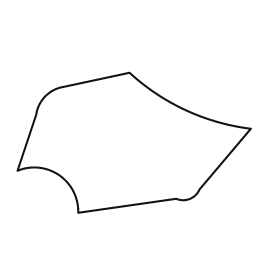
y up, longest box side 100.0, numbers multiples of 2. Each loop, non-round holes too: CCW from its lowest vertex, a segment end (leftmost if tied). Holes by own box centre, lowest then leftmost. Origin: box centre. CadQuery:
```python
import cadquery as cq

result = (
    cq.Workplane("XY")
    .moveTo(-24.0, -30.0)
    .lineTo(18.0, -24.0)
    .threePointArc((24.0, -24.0), (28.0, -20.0))
    .lineTo(50.0, 6.0)
    .threePointArc((22.0, 14.0), (-2.0, 30.0))
    .lineTo(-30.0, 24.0)
    .threePointArc((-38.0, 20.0), (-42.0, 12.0))
    .lineTo(-50.0, -12.0)
    .threePointArc((-32.0, -14.0), (-24.0, -30.0))
    .close()
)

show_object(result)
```